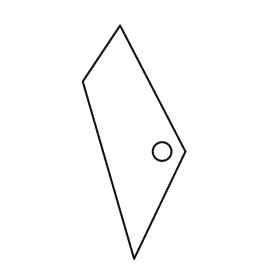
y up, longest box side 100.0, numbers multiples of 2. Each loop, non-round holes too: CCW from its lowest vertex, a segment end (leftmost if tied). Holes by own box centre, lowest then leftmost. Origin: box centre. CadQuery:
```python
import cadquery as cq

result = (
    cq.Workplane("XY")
    .moveTo(0.0, -50.0)
    .lineTo(22.0, -4.0)
    .lineTo(-6.0, 50.0)
    .lineTo(-22.0, 26.0)
    .close()
    .moveTo(12.0, -4.0)
    .circle(4.0)
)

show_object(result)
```